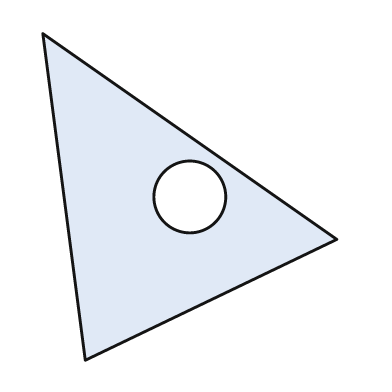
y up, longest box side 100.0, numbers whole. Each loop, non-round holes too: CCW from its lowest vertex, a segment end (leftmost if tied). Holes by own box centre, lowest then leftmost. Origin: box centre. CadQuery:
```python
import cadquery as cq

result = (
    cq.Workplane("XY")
    .moveTo(-32.0, -50.0)
    .lineTo(45.0, -13.0)
    .lineTo(-45.0, 50.0)
    .close()
    .moveTo(0.0, 0.0)
    .circle(11.0)
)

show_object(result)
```